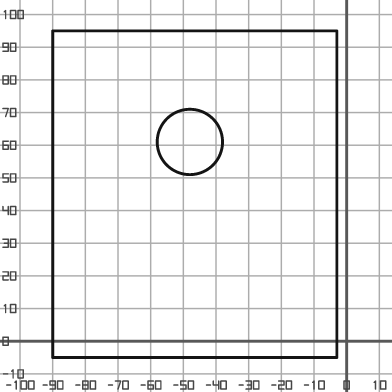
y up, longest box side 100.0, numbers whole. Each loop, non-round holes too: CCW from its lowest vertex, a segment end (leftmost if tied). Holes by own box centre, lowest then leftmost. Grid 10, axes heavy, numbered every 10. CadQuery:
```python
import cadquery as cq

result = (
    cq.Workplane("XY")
    .moveTo(-90.0, -5.0)
    .lineTo(-3.0, -5.0)
    .lineTo(-3.0, 95.0)
    .lineTo(-90.0, 95.0)
    .close()
    .moveTo(-48.0, 61.0)
    .circle(10.0)
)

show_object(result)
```